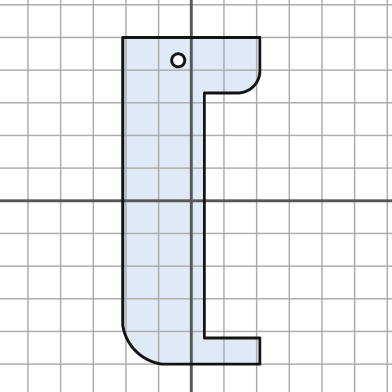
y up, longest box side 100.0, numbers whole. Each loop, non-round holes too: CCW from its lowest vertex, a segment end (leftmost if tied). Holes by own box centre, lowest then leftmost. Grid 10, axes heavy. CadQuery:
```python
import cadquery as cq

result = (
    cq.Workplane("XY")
    .moveTo(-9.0, -50.0)
    .lineTo(21.0, -50.0)
    .lineTo(21.0, -42.0)
    .lineTo(4.0, -42.0)
    .lineTo(4.0, 33.0)
    .lineTo(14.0, 33.0)
    .threePointArc((19.0, 35.0), (21.0, 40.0))
    .lineTo(21.0, 50.0)
    .lineTo(-21.0, 50.0)
    .lineTo(-21.0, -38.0)
    .threePointArc((-17.0, -46.0), (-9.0, -50.0))
    .close()
    .moveTo(-4.0, 43.0)
    .circle(2.0)
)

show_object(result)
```